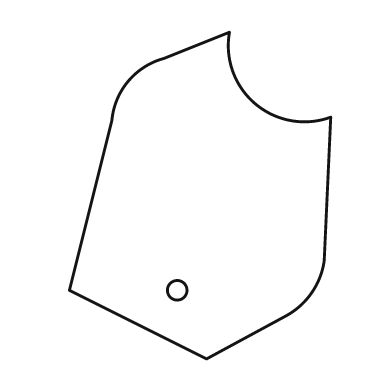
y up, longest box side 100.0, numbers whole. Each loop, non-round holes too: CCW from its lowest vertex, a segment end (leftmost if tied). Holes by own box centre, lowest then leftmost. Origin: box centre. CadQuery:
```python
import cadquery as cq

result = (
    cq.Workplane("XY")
    .moveTo(2.0, -50.0)
    .lineTo(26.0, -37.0)
    .threePointArc((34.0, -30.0), (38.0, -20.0))
    .lineTo(40.0, 24.0)
    .threePointArc((17.0, 28.0), (9.0, 50.0))
    .lineTo(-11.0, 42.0)
    .threePointArc((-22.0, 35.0), (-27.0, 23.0))
    .lineTo(-40.0, -29.0)
    .close()
    .moveTo(-7.0, -29.0)
    .circle(3.0)
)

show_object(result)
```